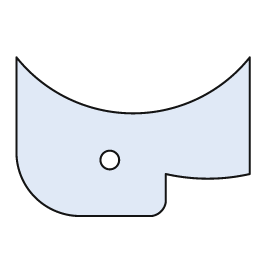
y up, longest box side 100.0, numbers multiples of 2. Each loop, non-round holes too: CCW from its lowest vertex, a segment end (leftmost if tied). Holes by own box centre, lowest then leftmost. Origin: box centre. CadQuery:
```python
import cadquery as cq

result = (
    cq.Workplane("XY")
    .moveTo(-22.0, -34.0)
    .lineTo(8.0, -34.0)
    .threePointArc((12.0, -32.0), (14.0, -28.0))
    .lineTo(14.0, -16.0)
    .threePointArc((32.0, -18.0), (50.0, -16.0))
    .lineTo(50.0, 34.0)
    .threePointArc((0.0, 10.0), (-50.0, 34.0))
    .lineTo(-50.0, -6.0)
    .threePointArc((-42.0, -26.0), (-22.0, -34.0))
    .close()
    .moveTo(-10.0, -10.0)
    .circle(4.0)
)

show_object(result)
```